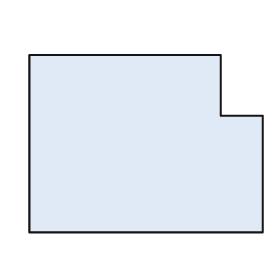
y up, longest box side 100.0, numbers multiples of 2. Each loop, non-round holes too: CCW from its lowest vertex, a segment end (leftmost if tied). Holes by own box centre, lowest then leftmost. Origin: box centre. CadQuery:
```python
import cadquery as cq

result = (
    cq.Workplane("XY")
    .moveTo(-50.0, -38.0)
    .lineTo(50.0, -38.0)
    .lineTo(50.0, 12.0)
    .lineTo(32.0, 12.0)
    .lineTo(32.0, 38.0)
    .lineTo(-50.0, 38.0)
    .close()
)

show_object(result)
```